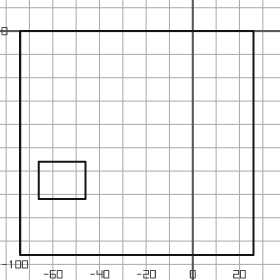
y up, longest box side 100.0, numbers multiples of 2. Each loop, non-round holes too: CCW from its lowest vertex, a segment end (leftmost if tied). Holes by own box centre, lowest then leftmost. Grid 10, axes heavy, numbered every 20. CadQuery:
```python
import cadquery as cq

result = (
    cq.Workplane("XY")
    .moveTo(-74.0, -96.0)
    .lineTo(26.0, -96.0)
    .lineTo(26.0, 0.0)
    .lineTo(-74.0, 0.0)
    .close()
    .moveTo(-66.0, -72.0)
    .lineTo(-46.0, -72.0)
    .lineTo(-46.0, -56.0)
    .lineTo(-66.0, -56.0)
    .close()
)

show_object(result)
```